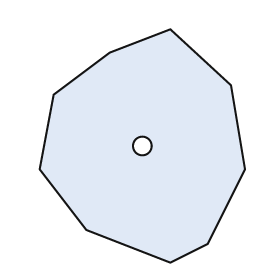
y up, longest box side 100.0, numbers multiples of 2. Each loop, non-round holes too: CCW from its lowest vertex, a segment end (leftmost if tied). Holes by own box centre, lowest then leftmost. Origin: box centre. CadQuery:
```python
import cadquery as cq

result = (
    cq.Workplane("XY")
    .moveTo(12.0, -50.0)
    .lineTo(28.0, -42.0)
    .lineTo(44.0, -10.0)
    .lineTo(38.0, 26.0)
    .lineTo(12.0, 50.0)
    .lineTo(-14.0, 40.0)
    .lineTo(-38.0, 22.0)
    .lineTo(-44.0, -10.0)
    .lineTo(-24.0, -36.0)
    .close()
    .moveTo(0.0, 0.0)
    .circle(4.0)
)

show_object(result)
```